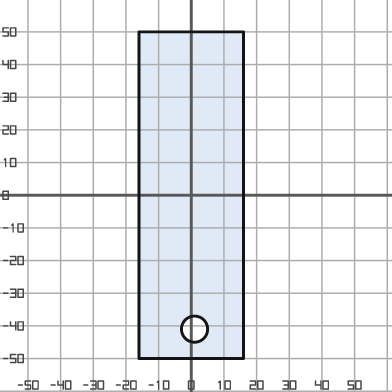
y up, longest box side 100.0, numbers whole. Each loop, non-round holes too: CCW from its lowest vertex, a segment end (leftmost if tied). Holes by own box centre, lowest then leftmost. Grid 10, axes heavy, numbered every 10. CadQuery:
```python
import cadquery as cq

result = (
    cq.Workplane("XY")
    .moveTo(-16.0, -50.0)
    .lineTo(16.0, -50.0)
    .lineTo(16.0, 50.0)
    .lineTo(-16.0, 50.0)
    .close()
    .moveTo(1.0, -41.0)
    .circle(4.0)
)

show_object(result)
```